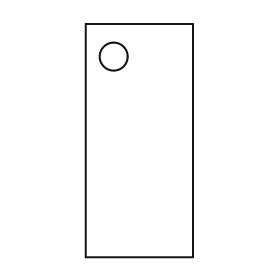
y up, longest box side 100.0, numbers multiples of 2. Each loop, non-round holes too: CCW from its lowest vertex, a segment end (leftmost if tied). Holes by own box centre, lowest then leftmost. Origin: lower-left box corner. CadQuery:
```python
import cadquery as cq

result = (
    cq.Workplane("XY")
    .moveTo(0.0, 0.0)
    .lineTo(46.0, 0.0)
    .lineTo(46.0, 100.0)
    .lineTo(0.0, 100.0)
    .close()
    .moveTo(12.0, 86.0)
    .circle(6.0)
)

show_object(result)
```